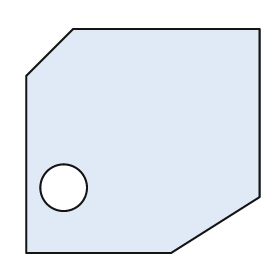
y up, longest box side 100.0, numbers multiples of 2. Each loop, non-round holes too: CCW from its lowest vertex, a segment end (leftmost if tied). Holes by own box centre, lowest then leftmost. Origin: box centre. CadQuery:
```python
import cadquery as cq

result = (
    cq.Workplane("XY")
    .moveTo(-50.0, -48.0)
    .lineTo(12.0, -48.0)
    .lineTo(50.0, -24.0)
    .lineTo(50.0, 48.0)
    .lineTo(-30.0, 48.0)
    .lineTo(-50.0, 28.0)
    .close()
    .moveTo(-34.0, -20.0)
    .circle(10.0)
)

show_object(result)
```